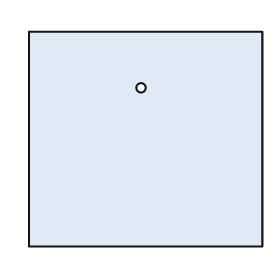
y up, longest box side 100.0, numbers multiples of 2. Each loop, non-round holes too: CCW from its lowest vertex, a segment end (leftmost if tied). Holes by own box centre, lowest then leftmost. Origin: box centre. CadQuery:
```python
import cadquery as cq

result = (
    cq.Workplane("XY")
    .moveTo(-50.0, -46.0)
    .lineTo(50.0, -46.0)
    .lineTo(50.0, 46.0)
    .lineTo(-50.0, 46.0)
    .close()
    .moveTo(-2.0, 22.0)
    .circle(2.0)
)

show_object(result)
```